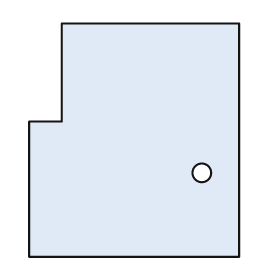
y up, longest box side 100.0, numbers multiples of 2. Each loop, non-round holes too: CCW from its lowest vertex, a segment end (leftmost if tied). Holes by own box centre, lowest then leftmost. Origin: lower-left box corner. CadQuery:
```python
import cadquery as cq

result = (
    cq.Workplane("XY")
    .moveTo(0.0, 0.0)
    .lineTo(90.0, 0.0)
    .lineTo(90.0, 100.0)
    .lineTo(14.0, 100.0)
    .lineTo(14.0, 58.0)
    .lineTo(0.0, 58.0)
    .close()
    .moveTo(74.0, 36.0)
    .circle(4.0)
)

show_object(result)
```